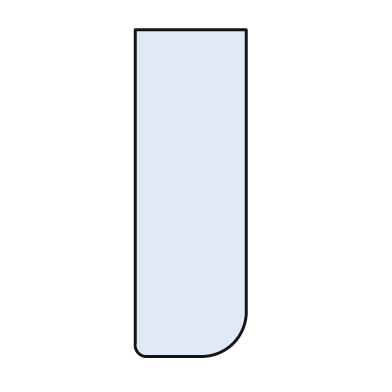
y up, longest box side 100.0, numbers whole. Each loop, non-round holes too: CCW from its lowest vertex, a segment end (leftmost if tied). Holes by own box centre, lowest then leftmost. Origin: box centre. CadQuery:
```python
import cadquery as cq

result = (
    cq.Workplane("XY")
    .moveTo(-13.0, -50.0)
    .lineTo(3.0, -50.0)
    .threePointArc((13.0, -46.0), (17.0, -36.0))
    .lineTo(17.0, 50.0)
    .lineTo(-17.0, 50.0)
    .lineTo(-17.0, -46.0)
    .threePointArc((-16.0, -49.0), (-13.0, -50.0))
    .close()
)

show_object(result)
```